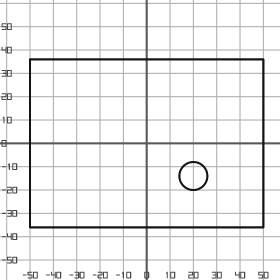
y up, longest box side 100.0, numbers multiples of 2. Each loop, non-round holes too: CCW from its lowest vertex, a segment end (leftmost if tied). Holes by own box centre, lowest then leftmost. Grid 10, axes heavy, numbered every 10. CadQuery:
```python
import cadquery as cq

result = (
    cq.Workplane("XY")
    .moveTo(-50.0, -36.0)
    .lineTo(50.0, -36.0)
    .lineTo(50.0, 36.0)
    .lineTo(-50.0, 36.0)
    .close()
    .moveTo(20.0, -14.0)
    .circle(6.0)
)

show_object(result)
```